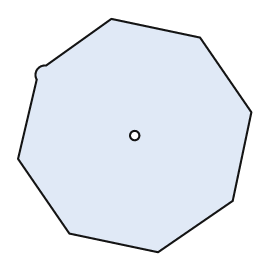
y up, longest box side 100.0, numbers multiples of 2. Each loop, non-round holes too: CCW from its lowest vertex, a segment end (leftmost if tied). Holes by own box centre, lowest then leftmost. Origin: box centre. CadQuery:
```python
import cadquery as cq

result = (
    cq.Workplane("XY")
    .moveTo(10.0, -50.0)
    .lineTo(42.0, -28.0)
    .lineTo(50.0, 10.0)
    .lineTo(28.0, 42.0)
    .lineTo(-10.0, 50.0)
    .lineTo(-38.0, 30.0)
    .threePointArc((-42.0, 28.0), (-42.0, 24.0))
    .lineTo(-50.0, -10.0)
    .lineTo(-28.0, -42.0)
    .close()
    .moveTo(0.0, 0.0)
    .circle(2.0)
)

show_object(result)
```